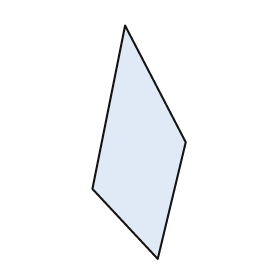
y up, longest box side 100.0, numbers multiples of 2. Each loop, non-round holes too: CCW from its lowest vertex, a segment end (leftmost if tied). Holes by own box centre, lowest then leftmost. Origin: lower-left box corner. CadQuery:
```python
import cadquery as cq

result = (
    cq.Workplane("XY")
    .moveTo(28.0, 0.0)
    .lineTo(40.0, 50.0)
    .lineTo(14.0, 100.0)
    .lineTo(0.0, 30.0)
    .close()
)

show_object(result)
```